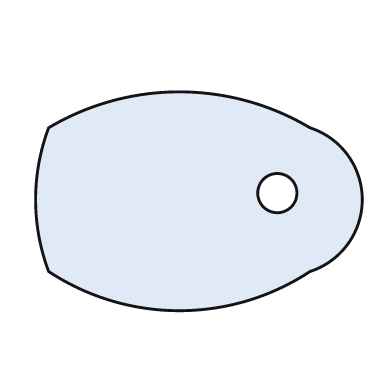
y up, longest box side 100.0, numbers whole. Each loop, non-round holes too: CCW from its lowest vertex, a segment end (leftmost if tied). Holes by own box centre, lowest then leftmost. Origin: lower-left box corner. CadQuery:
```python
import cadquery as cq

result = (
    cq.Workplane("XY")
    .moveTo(4.0, 12.0)
    .threePointArc((44.0, 0.0), (84.0, 12.0))
    .threePointArc((100.0, 34.0), (84.0, 56.0))
    .threePointArc((44.0, 67.0), (4.0, 56.0))
    .threePointArc((0.0, 34.0), (4.0, 12.0))
    .close()
    .moveTo(74.0, 36.0)
    .circle(6.0)
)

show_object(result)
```